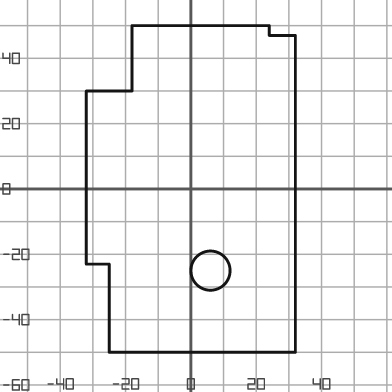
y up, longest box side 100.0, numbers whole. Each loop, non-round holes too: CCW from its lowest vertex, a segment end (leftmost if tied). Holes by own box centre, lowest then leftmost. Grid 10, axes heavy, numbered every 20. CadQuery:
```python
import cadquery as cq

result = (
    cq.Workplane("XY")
    .moveTo(-25.0, -50.0)
    .lineTo(32.0, -50.0)
    .lineTo(32.0, 47.0)
    .lineTo(24.0, 47.0)
    .lineTo(24.0, 50.0)
    .lineTo(-18.0, 50.0)
    .lineTo(-18.0, 30.0)
    .lineTo(-32.0, 30.0)
    .lineTo(-32.0, -23.0)
    .lineTo(-25.0, -23.0)
    .close()
    .moveTo(6.0, -25.0)
    .circle(6.0)
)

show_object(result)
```